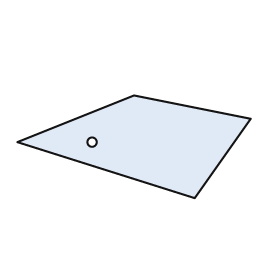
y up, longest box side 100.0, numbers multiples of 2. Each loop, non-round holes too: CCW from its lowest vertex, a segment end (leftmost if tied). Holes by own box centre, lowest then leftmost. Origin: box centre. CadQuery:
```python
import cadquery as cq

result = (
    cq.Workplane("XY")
    .moveTo(26.0, -22.0)
    .lineTo(50.0, 12.0)
    .lineTo(0.0, 22.0)
    .lineTo(-50.0, 2.0)
    .close()
    .moveTo(-18.0, 2.0)
    .circle(2.0)
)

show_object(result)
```